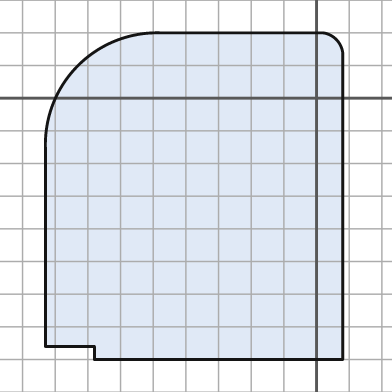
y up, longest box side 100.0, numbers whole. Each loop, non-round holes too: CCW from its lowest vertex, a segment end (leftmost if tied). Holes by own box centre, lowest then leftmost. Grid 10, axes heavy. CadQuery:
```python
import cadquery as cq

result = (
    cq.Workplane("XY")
    .moveTo(-68.0, -80.0)
    .lineTo(8.0, -80.0)
    .lineTo(8.0, 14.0)
    .threePointArc((6.0, 18.0), (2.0, 20.0))
    .lineTo(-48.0, 20.0)
    .threePointArc((-73.0, 10.0), (-83.0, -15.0))
    .lineTo(-83.0, -76.0)
    .lineTo(-68.0, -76.0)
    .close()
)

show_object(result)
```